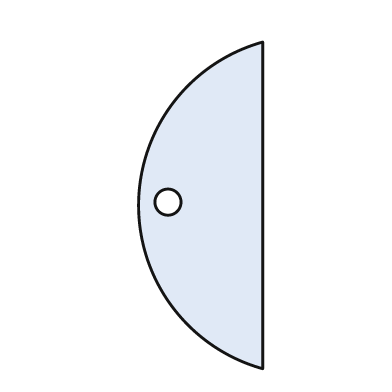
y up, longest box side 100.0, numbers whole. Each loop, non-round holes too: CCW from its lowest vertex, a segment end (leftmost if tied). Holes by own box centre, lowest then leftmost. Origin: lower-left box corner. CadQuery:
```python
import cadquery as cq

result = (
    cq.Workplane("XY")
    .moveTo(38.0, 0.0)
    .lineTo(38.0, 100.0)
    .threePointArc((0.0, 50.0), (38.0, 0.0))
    .close()
    .moveTo(9.0, 51.0)
    .circle(4.0)
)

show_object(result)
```